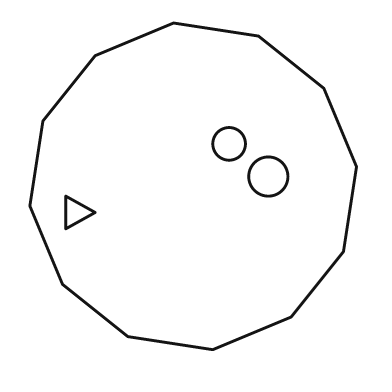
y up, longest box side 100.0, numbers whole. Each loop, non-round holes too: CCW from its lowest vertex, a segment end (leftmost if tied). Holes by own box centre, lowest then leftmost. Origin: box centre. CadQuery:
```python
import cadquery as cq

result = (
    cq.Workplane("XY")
    .moveTo(6.0, -50.0)
    .lineTo(30.0, -40.0)
    .lineTo(46.0, -20.0)
    .lineTo(50.0, 6.0)
    .lineTo(40.0, 30.0)
    .lineTo(20.0, 46.0)
    .lineTo(-6.0, 50.0)
    .lineTo(-30.0, 40.0)
    .lineTo(-46.0, 20.0)
    .lineTo(-50.0, -6.0)
    .lineTo(-40.0, -30.0)
    .lineTo(-20.0, -46.0)
    .close()
    .moveTo(-39.0, -13.0)
    .lineTo(-30.0, -8.0)
    .lineTo(-39.0, -3.0)
    .close()
    .moveTo(23.0, 3.0)
    .circle(6.0)
    .moveTo(11.0, 13.0)
    .circle(5.0)
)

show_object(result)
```